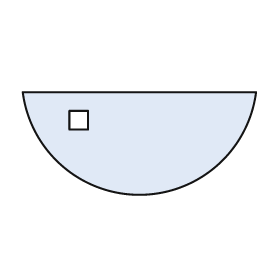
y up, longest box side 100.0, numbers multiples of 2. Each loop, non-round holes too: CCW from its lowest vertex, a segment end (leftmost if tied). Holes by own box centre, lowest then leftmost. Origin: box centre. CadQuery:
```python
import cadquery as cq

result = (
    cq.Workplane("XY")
    .moveTo(-50.0, 22.0)
    .threePointArc((0.0, -22.0), (50.0, 22.0))
    .close()
    .moveTo(-30.0, 6.0)
    .lineTo(-22.0, 6.0)
    .lineTo(-22.0, 14.0)
    .lineTo(-30.0, 14.0)
    .close()
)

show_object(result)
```